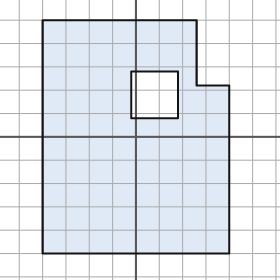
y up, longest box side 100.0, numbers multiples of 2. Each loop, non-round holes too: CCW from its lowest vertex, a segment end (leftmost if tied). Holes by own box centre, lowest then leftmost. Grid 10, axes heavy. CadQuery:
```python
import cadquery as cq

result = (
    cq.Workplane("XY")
    .moveTo(-40.0, -50.0)
    .lineTo(40.0, -50.0)
    .lineTo(40.0, 22.0)
    .lineTo(26.0, 22.0)
    .lineTo(26.0, 50.0)
    .lineTo(-40.0, 50.0)
    .close()
    .moveTo(-2.0, 8.0)
    .lineTo(18.0, 8.0)
    .lineTo(18.0, 28.0)
    .lineTo(-2.0, 28.0)
    .close()
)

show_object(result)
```